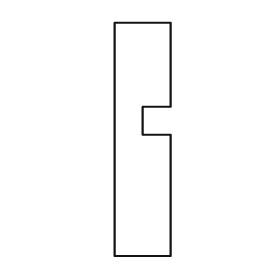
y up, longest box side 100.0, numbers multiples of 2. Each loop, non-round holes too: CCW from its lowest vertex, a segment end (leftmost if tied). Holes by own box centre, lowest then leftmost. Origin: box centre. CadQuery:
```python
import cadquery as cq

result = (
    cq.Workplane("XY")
    .moveTo(-12.0, -50.0)
    .lineTo(12.0, -50.0)
    .lineTo(12.0, 2.0)
    .lineTo(0.0, 2.0)
    .lineTo(0.0, 14.0)
    .lineTo(12.0, 14.0)
    .lineTo(12.0, 50.0)
    .lineTo(-12.0, 50.0)
    .close()
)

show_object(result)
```